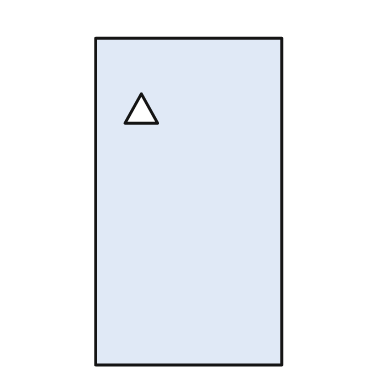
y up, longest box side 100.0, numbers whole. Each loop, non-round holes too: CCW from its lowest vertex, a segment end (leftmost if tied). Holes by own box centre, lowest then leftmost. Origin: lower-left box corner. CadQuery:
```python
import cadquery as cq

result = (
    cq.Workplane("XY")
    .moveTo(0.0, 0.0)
    .lineTo(57.0, 0.0)
    .lineTo(57.0, 100.0)
    .lineTo(0.0, 100.0)
    .close()
    .moveTo(9.0, 74.0)
    .lineTo(19.0, 74.0)
    .lineTo(14.0, 83.0)
    .close()
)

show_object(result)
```